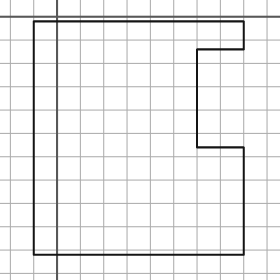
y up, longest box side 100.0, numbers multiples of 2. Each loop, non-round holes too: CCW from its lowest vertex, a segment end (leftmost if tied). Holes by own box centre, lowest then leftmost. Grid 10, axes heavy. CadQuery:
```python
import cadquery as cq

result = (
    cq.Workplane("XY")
    .moveTo(-10.0, -102.0)
    .lineTo(80.0, -102.0)
    .lineTo(80.0, -56.0)
    .lineTo(60.0, -56.0)
    .lineTo(60.0, -14.0)
    .lineTo(80.0, -14.0)
    .lineTo(80.0, -2.0)
    .lineTo(-10.0, -2.0)
    .close()
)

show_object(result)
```